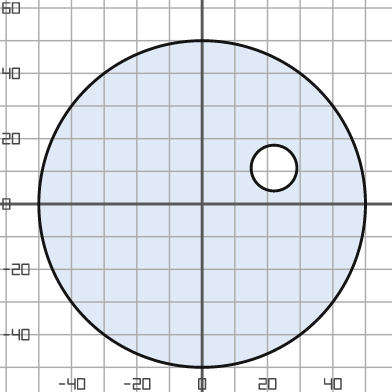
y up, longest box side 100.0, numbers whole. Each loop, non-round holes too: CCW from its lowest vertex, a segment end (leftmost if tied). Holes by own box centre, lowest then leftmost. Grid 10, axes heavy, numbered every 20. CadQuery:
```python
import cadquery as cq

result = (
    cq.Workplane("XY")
    .moveTo(0.0, 0.0)
    .circle(50.0)
    .moveTo(22.0, 11.0)
    .circle(7.0)
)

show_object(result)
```